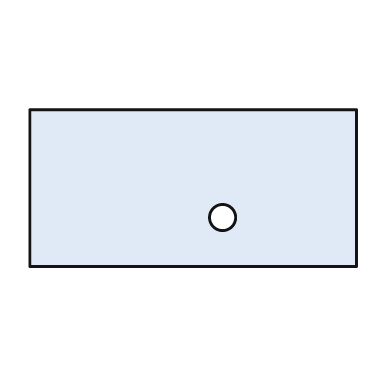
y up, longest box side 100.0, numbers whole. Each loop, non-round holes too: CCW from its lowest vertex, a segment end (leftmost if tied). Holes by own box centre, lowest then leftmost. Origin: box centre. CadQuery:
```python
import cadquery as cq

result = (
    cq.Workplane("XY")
    .moveTo(-50.0, -24.0)
    .lineTo(50.0, -24.0)
    .lineTo(50.0, 24.0)
    .lineTo(-50.0, 24.0)
    .close()
    .moveTo(9.0, -9.0)
    .circle(4.0)
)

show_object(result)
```